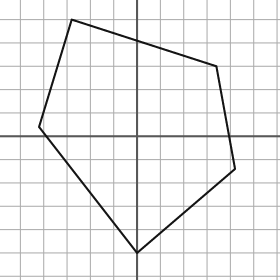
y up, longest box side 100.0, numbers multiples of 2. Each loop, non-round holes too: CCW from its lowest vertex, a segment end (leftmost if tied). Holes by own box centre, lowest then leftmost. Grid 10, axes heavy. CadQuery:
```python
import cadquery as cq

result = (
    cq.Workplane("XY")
    .moveTo(0.0, -50.0)
    .lineTo(42.0, -14.0)
    .lineTo(34.0, 30.0)
    .lineTo(-28.0, 50.0)
    .lineTo(-42.0, 4.0)
    .close()
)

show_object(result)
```